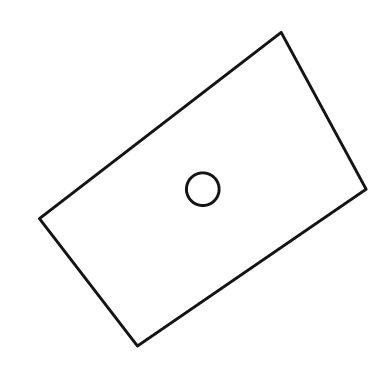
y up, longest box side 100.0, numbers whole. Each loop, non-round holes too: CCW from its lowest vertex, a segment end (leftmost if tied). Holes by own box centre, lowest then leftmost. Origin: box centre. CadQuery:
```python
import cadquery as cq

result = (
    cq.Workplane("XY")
    .moveTo(-20.0, -48.0)
    .lineTo(50.0, 0.0)
    .lineTo(24.0, 48.0)
    .lineTo(-50.0, -9.0)
    .close()
    .moveTo(0.0, 0.0)
    .circle(5.0)
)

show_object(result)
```